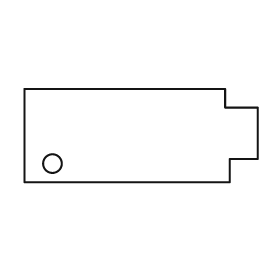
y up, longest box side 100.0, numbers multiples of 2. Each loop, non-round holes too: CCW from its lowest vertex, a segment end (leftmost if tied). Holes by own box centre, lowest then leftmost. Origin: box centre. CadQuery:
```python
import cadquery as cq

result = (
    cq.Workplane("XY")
    .moveTo(-50.0, -20.0)
    .lineTo(38.0, -20.0)
    .lineTo(38.0, -10.0)
    .lineTo(50.0, -10.0)
    .lineTo(50.0, 12.0)
    .lineTo(36.0, 12.0)
    .lineTo(36.0, 20.0)
    .lineTo(-50.0, 20.0)
    .close()
    .moveTo(-38.0, -12.0)
    .circle(4.0)
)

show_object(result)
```